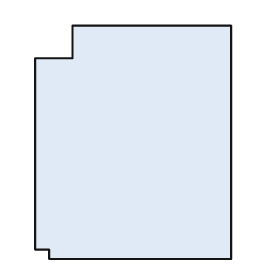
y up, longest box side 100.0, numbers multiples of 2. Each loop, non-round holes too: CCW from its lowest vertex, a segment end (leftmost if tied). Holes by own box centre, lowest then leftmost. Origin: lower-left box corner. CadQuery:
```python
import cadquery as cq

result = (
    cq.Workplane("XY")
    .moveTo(6.0, 0.0)
    .lineTo(84.0, 0.0)
    .lineTo(84.0, 100.0)
    .lineTo(16.0, 100.0)
    .lineTo(16.0, 86.0)
    .lineTo(0.0, 86.0)
    .lineTo(0.0, 4.0)
    .lineTo(6.0, 4.0)
    .close()
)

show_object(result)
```